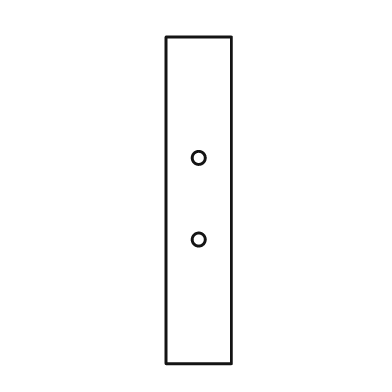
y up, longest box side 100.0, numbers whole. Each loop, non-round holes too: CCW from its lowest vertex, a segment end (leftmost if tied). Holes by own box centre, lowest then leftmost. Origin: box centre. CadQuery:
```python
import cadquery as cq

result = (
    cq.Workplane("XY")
    .moveTo(-10.0, -50.0)
    .lineTo(10.0, -50.0)
    .lineTo(10.0, 50.0)
    .lineTo(-10.0, 50.0)
    .close()
    .moveTo(0.0, -12.0)
    .circle(2.0)
    .moveTo(0.0, 13.0)
    .circle(2.0)
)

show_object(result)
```